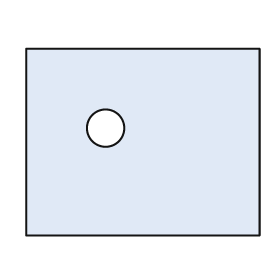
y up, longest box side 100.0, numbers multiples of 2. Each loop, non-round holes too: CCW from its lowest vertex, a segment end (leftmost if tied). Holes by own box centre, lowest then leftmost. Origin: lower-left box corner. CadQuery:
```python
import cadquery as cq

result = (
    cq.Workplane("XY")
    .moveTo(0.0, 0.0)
    .lineTo(100.0, 0.0)
    .lineTo(100.0, 80.0)
    .lineTo(0.0, 80.0)
    .close()
    .moveTo(34.0, 46.0)
    .circle(8.0)
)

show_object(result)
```